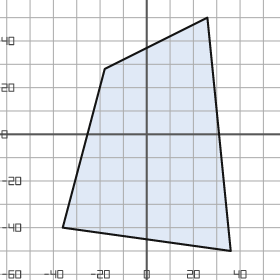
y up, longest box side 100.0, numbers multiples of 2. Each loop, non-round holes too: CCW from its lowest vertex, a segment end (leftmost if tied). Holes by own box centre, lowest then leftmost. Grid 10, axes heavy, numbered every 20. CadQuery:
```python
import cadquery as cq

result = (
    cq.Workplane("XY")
    .moveTo(36.0, -50.0)
    .lineTo(26.0, 50.0)
    .lineTo(-18.0, 28.0)
    .lineTo(-36.0, -40.0)
    .close()
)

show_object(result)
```